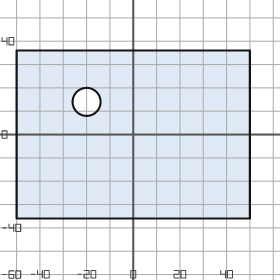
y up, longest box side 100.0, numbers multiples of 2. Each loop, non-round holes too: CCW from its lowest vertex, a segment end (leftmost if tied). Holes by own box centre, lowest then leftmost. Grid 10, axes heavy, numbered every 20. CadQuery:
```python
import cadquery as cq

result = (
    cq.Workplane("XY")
    .moveTo(-50.0, -36.0)
    .lineTo(50.0, -36.0)
    .lineTo(50.0, 36.0)
    .lineTo(-50.0, 36.0)
    .close()
    .moveTo(-20.0, 14.0)
    .circle(6.0)
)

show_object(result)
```